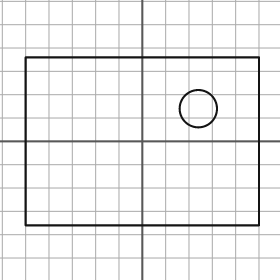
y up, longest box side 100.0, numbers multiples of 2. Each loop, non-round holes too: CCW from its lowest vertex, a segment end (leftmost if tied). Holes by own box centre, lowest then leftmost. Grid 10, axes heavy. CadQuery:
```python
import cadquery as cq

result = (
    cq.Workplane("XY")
    .moveTo(-50.0, -36.0)
    .lineTo(50.0, -36.0)
    .lineTo(50.0, 36.0)
    .lineTo(-50.0, 36.0)
    .close()
    .moveTo(24.0, 14.0)
    .circle(8.0)
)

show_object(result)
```